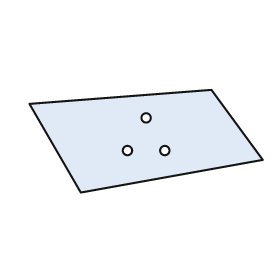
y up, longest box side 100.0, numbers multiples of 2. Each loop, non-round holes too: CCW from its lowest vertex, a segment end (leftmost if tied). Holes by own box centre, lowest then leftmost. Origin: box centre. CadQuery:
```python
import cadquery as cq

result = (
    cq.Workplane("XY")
    .moveTo(-28.0, -22.0)
    .lineTo(50.0, -8.0)
    .lineTo(28.0, 22.0)
    .lineTo(-50.0, 16.0)
    .close()
    .moveTo(-8.0, -4.0)
    .circle(2.0)
    .moveTo(8.0, -4.0)
    .circle(2.0)
    .moveTo(0.0, 10.0)
    .circle(2.0)
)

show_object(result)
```